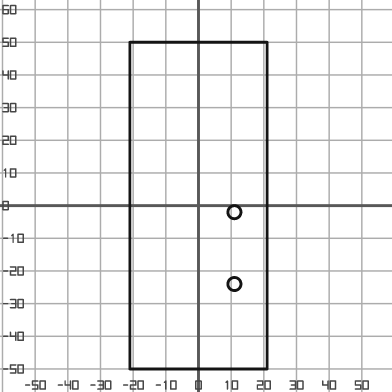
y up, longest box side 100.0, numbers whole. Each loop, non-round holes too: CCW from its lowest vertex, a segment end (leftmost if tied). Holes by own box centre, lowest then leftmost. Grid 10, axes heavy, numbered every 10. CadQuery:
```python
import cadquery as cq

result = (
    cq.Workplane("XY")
    .moveTo(-21.0, -50.0)
    .lineTo(21.0, -50.0)
    .lineTo(21.0, 50.0)
    .lineTo(-21.0, 50.0)
    .close()
    .moveTo(11.0, -24.0)
    .circle(2.0)
    .moveTo(11.0, -2.0)
    .circle(2.0)
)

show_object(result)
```